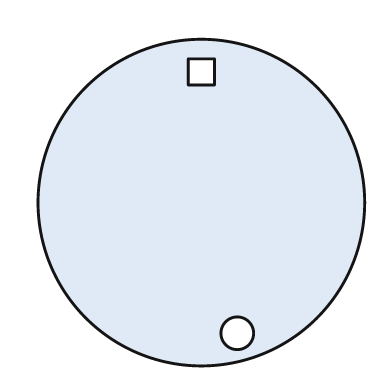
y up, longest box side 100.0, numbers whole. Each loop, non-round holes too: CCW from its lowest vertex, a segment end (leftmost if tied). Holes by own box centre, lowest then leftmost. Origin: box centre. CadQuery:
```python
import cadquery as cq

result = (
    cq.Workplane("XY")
    .moveTo(0.0, 0.0)
    .circle(50.0)
    .moveTo(11.0, -40.0)
    .circle(5.0)
    .moveTo(-4.0, 36.0)
    .lineTo(4.0, 36.0)
    .lineTo(4.0, 44.0)
    .lineTo(-4.0, 44.0)
    .close()
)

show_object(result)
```